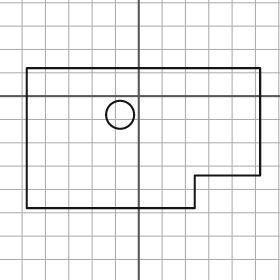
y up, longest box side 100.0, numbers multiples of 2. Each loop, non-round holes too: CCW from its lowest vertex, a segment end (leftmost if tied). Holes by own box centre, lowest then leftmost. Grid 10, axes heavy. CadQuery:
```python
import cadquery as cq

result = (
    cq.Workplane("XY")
    .moveTo(-48.0, -48.0)
    .lineTo(24.0, -48.0)
    .lineTo(24.0, -34.0)
    .lineTo(52.0, -34.0)
    .lineTo(52.0, 12.0)
    .lineTo(-48.0, 12.0)
    .close()
    .moveTo(-8.0, -8.0)
    .circle(6.0)
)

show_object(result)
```